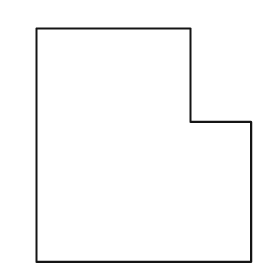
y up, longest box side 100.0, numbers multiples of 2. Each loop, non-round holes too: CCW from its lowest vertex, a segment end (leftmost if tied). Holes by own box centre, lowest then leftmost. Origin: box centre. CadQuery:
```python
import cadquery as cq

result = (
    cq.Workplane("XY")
    .moveTo(-46.0, -50.0)
    .lineTo(46.0, -50.0)
    .lineTo(46.0, 10.0)
    .lineTo(20.0, 10.0)
    .lineTo(20.0, 50.0)
    .lineTo(-46.0, 50.0)
    .close()
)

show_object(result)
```